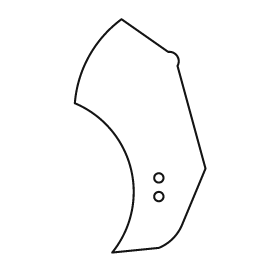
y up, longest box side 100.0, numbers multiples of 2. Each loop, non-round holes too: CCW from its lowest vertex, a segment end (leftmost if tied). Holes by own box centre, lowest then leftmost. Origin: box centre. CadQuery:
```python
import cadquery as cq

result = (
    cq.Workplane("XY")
    .moveTo(-12.0, -50.0)
    .lineTo(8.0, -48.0)
    .threePointArc((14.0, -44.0), (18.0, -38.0))
    .lineTo(28.0, -14.0)
    .lineTo(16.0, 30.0)
    .threePointArc((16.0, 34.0), (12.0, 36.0))
    .lineTo(-8.0, 50.0)
    .threePointArc((-22.0, 34.0), (-28.0, 14.0))
    .threePointArc((-4.0, -14.0), (-12.0, -50.0))
    .close()
    .moveTo(8.0, -26.0)
    .circle(2.0)
    .moveTo(8.0, -18.0)
    .circle(2.0)
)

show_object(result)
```